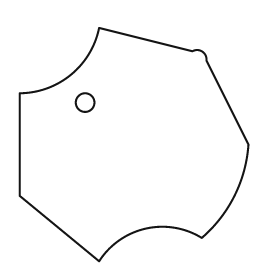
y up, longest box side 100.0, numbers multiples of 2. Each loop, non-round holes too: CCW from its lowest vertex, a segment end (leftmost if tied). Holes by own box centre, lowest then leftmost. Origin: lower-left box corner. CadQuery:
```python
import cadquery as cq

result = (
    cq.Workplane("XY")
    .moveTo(34.0, 0.0)
    .threePointArc((54.0, 14.0), (78.0, 10.0))
    .threePointArc((92.0, 28.0), (98.0, 50.0))
    .lineTo(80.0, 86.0)
    .threePointArc((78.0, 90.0), (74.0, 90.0))
    .lineTo(34.0, 100.0)
    .threePointArc((22.0, 80.0), (0.0, 72.0))
    .lineTo(0.0, 28.0)
    .close()
    .moveTo(28.0, 68.0)
    .circle(4.0)
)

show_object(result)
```